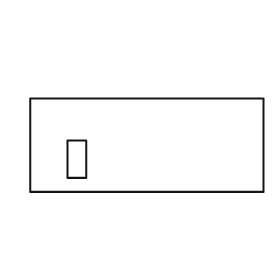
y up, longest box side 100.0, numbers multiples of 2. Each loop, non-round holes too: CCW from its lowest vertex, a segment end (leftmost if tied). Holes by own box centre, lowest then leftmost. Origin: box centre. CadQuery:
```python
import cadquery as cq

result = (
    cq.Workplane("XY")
    .moveTo(-50.0, -20.0)
    .lineTo(50.0, -20.0)
    .lineTo(50.0, 20.0)
    .lineTo(-50.0, 20.0)
    .close()
    .moveTo(-34.0, -14.0)
    .lineTo(-26.0, -14.0)
    .lineTo(-26.0, 2.0)
    .lineTo(-34.0, 2.0)
    .close()
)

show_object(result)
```